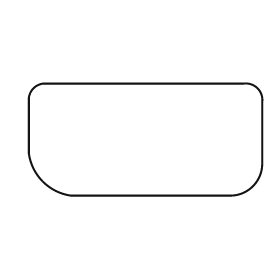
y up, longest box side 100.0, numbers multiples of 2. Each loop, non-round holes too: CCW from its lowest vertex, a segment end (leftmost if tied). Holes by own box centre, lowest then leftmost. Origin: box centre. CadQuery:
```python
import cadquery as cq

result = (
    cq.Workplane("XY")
    .moveTo(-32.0, -24.0)
    .lineTo(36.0, -24.0)
    .threePointArc((46.0, -20.0), (50.0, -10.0))
    .lineTo(50.0, 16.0)
    .threePointArc((48.0, 22.0), (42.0, 24.0))
    .lineTo(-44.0, 24.0)
    .threePointArc((-48.0, 22.0), (-50.0, 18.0))
    .lineTo(-50.0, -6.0)
    .threePointArc((-44.0, -18.0), (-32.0, -24.0))
    .close()
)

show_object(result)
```